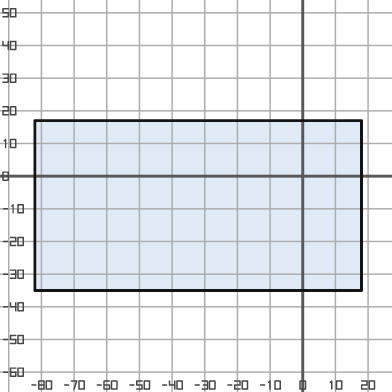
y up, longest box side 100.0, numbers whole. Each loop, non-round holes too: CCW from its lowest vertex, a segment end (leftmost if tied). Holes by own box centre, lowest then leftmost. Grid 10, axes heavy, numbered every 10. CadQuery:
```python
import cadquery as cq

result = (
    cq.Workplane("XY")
    .moveTo(-82.0, -35.0)
    .lineTo(18.0, -35.0)
    .lineTo(18.0, 17.0)
    .lineTo(-82.0, 17.0)
    .close()
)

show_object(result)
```